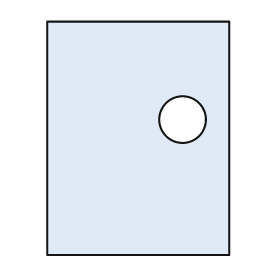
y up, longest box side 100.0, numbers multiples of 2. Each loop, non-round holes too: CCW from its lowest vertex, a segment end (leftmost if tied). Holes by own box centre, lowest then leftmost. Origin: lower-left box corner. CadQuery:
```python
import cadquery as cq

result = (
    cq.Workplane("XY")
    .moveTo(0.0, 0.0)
    .lineTo(78.0, 0.0)
    .lineTo(78.0, 100.0)
    .lineTo(0.0, 100.0)
    .close()
    .moveTo(58.0, 58.0)
    .circle(10.0)
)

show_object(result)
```